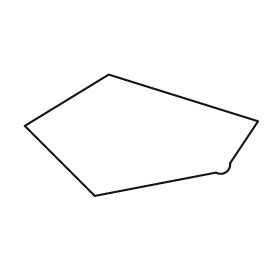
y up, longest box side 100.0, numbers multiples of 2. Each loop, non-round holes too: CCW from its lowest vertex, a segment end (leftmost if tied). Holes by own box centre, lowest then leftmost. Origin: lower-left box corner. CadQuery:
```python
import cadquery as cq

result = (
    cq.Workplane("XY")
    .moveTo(30.0, 0.0)
    .lineTo(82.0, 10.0)
    .threePointArc((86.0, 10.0), (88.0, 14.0))
    .lineTo(100.0, 32.0)
    .lineTo(36.0, 52.0)
    .lineTo(0.0, 30.0)
    .close()
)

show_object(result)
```